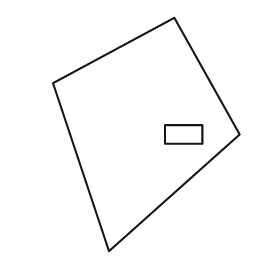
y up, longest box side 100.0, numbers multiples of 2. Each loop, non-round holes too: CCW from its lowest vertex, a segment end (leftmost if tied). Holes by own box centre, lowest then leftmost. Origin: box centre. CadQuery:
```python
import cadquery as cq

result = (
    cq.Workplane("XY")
    .moveTo(-16.0, -50.0)
    .lineTo(40.0, 0.0)
    .lineTo(12.0, 50.0)
    .lineTo(-40.0, 22.0)
    .close()
    .moveTo(8.0, -4.0)
    .lineTo(24.0, -4.0)
    .lineTo(24.0, 4.0)
    .lineTo(8.0, 4.0)
    .close()
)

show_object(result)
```